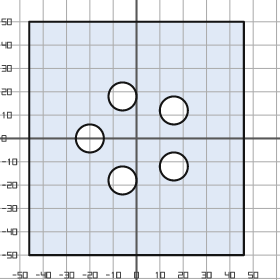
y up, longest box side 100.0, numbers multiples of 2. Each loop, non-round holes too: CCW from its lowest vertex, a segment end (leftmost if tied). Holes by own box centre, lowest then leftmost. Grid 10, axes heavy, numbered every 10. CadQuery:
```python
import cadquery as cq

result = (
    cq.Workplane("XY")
    .moveTo(-46.0, -50.0)
    .lineTo(46.0, -50.0)
    .lineTo(46.0, 50.0)
    .lineTo(-46.0, 50.0)
    .close()
    .moveTo(-6.0, -18.0)
    .circle(6.0)
    .moveTo(16.0, -12.0)
    .circle(6.0)
    .moveTo(-20.0, 0.0)
    .circle(6.0)
    .moveTo(16.0, 12.0)
    .circle(6.0)
    .moveTo(-6.0, 18.0)
    .circle(6.0)
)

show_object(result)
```